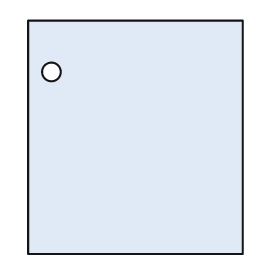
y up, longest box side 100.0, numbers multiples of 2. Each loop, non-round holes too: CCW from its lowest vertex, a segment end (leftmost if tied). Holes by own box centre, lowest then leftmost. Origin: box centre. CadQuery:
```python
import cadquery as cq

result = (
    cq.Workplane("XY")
    .moveTo(-46.0, -50.0)
    .lineTo(46.0, -50.0)
    .lineTo(46.0, 50.0)
    .lineTo(-46.0, 50.0)
    .close()
    .moveTo(-36.0, 28.0)
    .circle(4.0)
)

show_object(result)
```